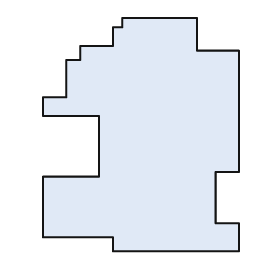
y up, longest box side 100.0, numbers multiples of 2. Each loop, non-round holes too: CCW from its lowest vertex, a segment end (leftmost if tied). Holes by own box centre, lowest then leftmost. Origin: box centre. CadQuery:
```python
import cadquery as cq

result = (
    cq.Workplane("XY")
    .moveTo(-12.0, -50.0)
    .lineTo(42.0, -50.0)
    .lineTo(42.0, -38.0)
    .lineTo(32.0, -38.0)
    .lineTo(32.0, -16.0)
    .lineTo(42.0, -16.0)
    .lineTo(42.0, 36.0)
    .lineTo(24.0, 36.0)
    .lineTo(24.0, 50.0)
    .lineTo(-8.0, 50.0)
    .lineTo(-8.0, 46.0)
    .lineTo(-12.0, 46.0)
    .lineTo(-12.0, 38.0)
    .lineTo(-26.0, 38.0)
    .lineTo(-26.0, 32.0)
    .lineTo(-32.0, 32.0)
    .lineTo(-32.0, 16.0)
    .lineTo(-42.0, 16.0)
    .lineTo(-42.0, 8.0)
    .lineTo(-18.0, 8.0)
    .lineTo(-18.0, -18.0)
    .lineTo(-42.0, -18.0)
    .lineTo(-42.0, -44.0)
    .lineTo(-12.0, -44.0)
    .close()
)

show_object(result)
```